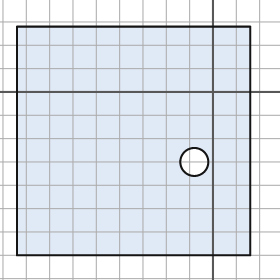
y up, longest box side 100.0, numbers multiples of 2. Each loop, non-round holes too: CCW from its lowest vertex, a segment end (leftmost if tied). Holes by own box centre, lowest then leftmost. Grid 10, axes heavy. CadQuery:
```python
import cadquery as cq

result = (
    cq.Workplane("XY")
    .moveTo(-84.0, -70.0)
    .lineTo(16.0, -70.0)
    .lineTo(16.0, 28.0)
    .lineTo(-84.0, 28.0)
    .close()
    .moveTo(-8.0, -30.0)
    .circle(6.0)
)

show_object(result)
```